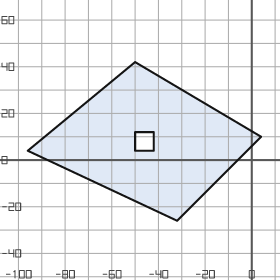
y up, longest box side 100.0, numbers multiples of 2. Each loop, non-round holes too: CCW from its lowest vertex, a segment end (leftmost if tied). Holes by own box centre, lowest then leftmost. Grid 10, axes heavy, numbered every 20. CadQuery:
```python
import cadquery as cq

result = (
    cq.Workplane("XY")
    .moveTo(-32.0, -26.0)
    .lineTo(4.0, 10.0)
    .lineTo(-50.0, 42.0)
    .lineTo(-96.0, 4.0)
    .close()
    .moveTo(-50.0, 4.0)
    .lineTo(-42.0, 4.0)
    .lineTo(-42.0, 12.0)
    .lineTo(-50.0, 12.0)
    .close()
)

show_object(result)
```